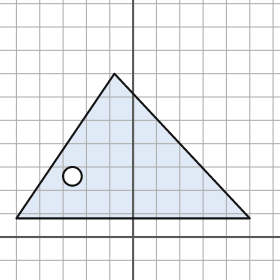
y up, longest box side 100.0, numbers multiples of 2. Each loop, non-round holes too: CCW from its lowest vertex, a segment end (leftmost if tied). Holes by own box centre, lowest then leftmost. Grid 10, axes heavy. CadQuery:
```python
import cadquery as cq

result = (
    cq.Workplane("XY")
    .moveTo(-50.0, 8.0)
    .lineTo(50.0, 8.0)
    .lineTo(-8.0, 70.0)
    .close()
    .moveTo(-26.0, 26.0)
    .circle(4.0)
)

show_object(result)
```